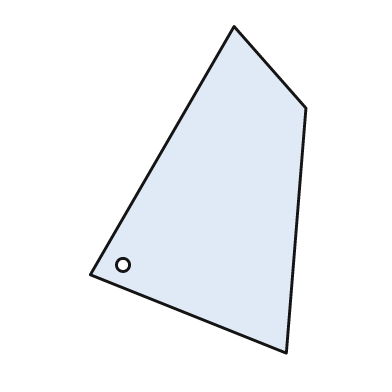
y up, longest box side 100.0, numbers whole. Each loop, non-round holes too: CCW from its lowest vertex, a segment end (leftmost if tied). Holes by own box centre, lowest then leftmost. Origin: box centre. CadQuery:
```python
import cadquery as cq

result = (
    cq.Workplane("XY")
    .moveTo(27.0, -50.0)
    .lineTo(33.0, 25.0)
    .lineTo(11.0, 50.0)
    .lineTo(-33.0, -26.0)
    .close()
    .moveTo(-23.0, -23.0)
    .circle(2.0)
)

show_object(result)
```